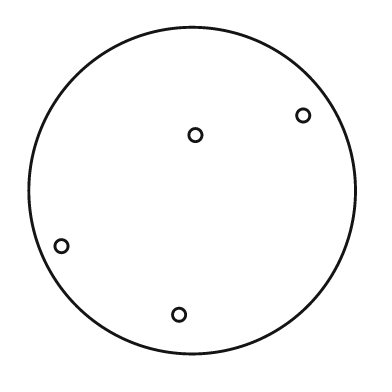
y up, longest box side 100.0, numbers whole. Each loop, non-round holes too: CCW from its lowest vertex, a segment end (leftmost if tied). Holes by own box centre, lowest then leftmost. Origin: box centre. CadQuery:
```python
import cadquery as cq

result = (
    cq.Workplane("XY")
    .moveTo(0.0, 0.0)
    .circle(50.0)
    .moveTo(-4.0, -38.0)
    .circle(2.0)
    .moveTo(-40.0, -17.0)
    .circle(2.0)
    .moveTo(1.0, 17.0)
    .circle(2.0)
    .moveTo(34.0, 23.0)
    .circle(2.0)
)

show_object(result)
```